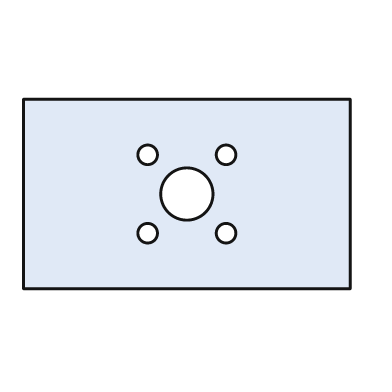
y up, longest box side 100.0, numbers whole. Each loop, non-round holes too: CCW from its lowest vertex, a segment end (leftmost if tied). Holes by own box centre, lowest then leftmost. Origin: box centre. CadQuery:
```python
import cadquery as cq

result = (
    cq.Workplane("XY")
    .moveTo(-50.0, -29.0)
    .lineTo(50.0, -29.0)
    .lineTo(50.0, 29.0)
    .lineTo(-50.0, 29.0)
    .close()
    .moveTo(-12.0, -12.0)
    .circle(3.0)
    .moveTo(12.0, -12.0)
    .circle(3.0)
    .moveTo(0.0, 0.0)
    .circle(8.0)
    .moveTo(-12.0, 12.0)
    .circle(3.0)
    .moveTo(12.0, 12.0)
    .circle(3.0)
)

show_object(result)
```